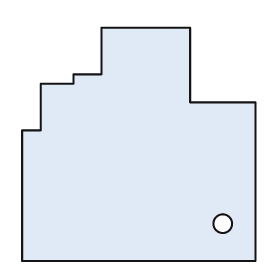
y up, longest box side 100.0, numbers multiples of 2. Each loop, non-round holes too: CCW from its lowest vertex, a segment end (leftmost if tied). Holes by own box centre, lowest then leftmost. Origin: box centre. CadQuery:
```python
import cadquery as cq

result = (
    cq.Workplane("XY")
    .moveTo(-50.0, -50.0)
    .lineTo(50.0, -50.0)
    .lineTo(50.0, 18.0)
    .lineTo(22.0, 18.0)
    .lineTo(22.0, 50.0)
    .lineTo(-16.0, 50.0)
    .lineTo(-16.0, 30.0)
    .lineTo(-28.0, 30.0)
    .lineTo(-28.0, 26.0)
    .lineTo(-42.0, 26.0)
    .lineTo(-42.0, 6.0)
    .lineTo(-50.0, 6.0)
    .close()
    .moveTo(36.0, -34.0)
    .circle(4.0)
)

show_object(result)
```